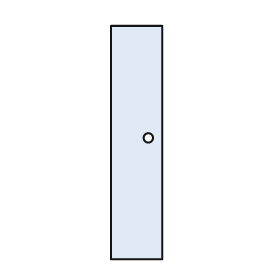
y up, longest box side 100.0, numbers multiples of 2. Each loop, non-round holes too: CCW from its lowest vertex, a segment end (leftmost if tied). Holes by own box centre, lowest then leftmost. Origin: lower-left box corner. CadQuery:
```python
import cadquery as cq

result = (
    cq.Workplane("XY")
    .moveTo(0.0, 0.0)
    .lineTo(22.0, 0.0)
    .lineTo(22.0, 100.0)
    .lineTo(0.0, 100.0)
    .close()
    .moveTo(16.0, 52.0)
    .circle(2.0)
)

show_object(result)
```